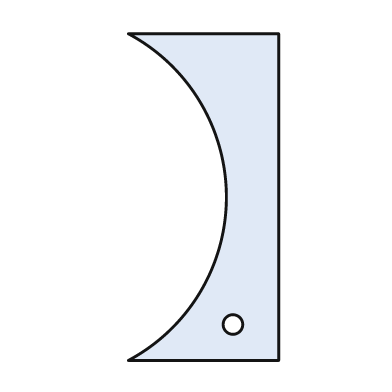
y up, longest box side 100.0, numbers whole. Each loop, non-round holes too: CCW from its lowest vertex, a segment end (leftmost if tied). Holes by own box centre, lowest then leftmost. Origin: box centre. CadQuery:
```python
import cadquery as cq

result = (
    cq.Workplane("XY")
    .moveTo(-23.0, -50.0)
    .lineTo(23.0, -50.0)
    .lineTo(23.0, 50.0)
    .lineTo(-23.0, 50.0)
    .threePointArc((7.0, 0.0), (-23.0, -50.0))
    .close()
    .moveTo(9.0, -39.0)
    .circle(3.0)
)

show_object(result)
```